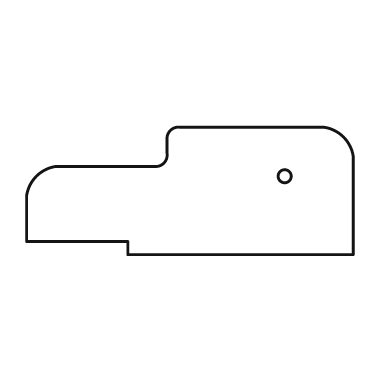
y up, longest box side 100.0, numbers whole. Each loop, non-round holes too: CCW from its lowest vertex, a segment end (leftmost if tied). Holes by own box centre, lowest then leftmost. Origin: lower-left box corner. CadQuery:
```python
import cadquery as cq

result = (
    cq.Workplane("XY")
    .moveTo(31.0, 0.0)
    .lineTo(100.0, 0.0)
    .lineTo(100.0, 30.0)
    .threePointArc((97.0, 36.0), (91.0, 39.0))
    .lineTo(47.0, 39.0)
    .threePointArc((44.0, 38.0), (43.0, 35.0))
    .lineTo(43.0, 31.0)
    .threePointArc((42.0, 28.0), (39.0, 27.0))
    .lineTo(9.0, 27.0)
    .threePointArc((3.0, 24.0), (0.0, 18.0))
    .lineTo(0.0, 4.0)
    .lineTo(31.0, 4.0)
    .close()
    .moveTo(79.0, 24.0)
    .circle(2.0)
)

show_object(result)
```